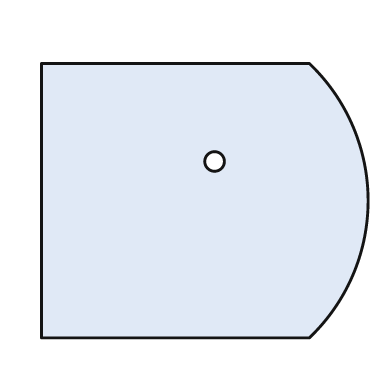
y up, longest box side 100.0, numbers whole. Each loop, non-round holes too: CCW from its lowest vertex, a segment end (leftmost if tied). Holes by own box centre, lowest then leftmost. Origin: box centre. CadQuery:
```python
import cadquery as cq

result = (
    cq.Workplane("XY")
    .moveTo(-50.0, -42.0)
    .lineTo(32.0, -42.0)
    .threePointArc((50.0, 0.0), (32.0, 42.0))
    .lineTo(-50.0, 42.0)
    .close()
    .moveTo(3.0, 12.0)
    .circle(3.0)
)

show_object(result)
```